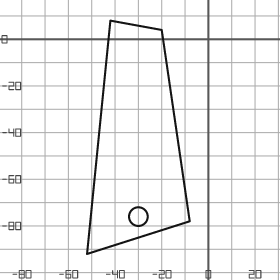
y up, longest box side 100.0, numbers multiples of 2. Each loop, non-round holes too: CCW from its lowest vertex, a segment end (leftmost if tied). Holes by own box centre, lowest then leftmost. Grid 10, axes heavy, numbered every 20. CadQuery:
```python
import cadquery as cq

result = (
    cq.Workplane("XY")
    .moveTo(-52.0, -92.0)
    .lineTo(-8.0, -78.0)
    .lineTo(-20.0, 4.0)
    .lineTo(-42.0, 8.0)
    .close()
    .moveTo(-30.0, -76.0)
    .circle(4.0)
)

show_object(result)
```